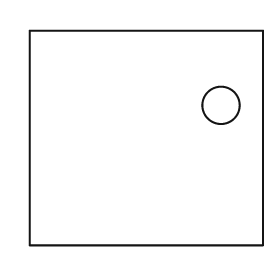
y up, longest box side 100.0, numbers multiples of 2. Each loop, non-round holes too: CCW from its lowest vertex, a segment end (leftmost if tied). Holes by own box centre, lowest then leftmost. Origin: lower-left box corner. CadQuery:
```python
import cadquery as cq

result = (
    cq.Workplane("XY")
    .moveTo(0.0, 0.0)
    .lineTo(100.0, 0.0)
    .lineTo(100.0, 92.0)
    .lineTo(0.0, 92.0)
    .close()
    .moveTo(82.0, 60.0)
    .circle(8.0)
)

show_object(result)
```